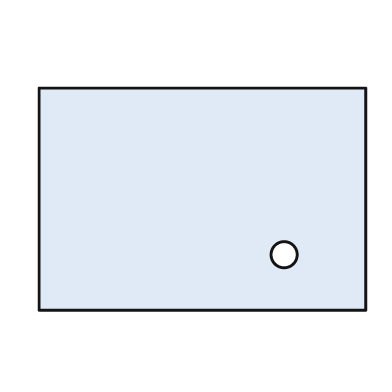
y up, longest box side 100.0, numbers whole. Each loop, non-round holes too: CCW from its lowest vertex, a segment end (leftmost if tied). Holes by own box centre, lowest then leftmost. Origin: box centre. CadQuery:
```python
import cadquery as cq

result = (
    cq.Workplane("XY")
    .moveTo(-50.0, -34.0)
    .lineTo(50.0, -34.0)
    .lineTo(50.0, 34.0)
    .lineTo(-50.0, 34.0)
    .close()
    .moveTo(25.0, -17.0)
    .circle(4.0)
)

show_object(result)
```